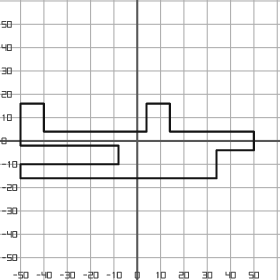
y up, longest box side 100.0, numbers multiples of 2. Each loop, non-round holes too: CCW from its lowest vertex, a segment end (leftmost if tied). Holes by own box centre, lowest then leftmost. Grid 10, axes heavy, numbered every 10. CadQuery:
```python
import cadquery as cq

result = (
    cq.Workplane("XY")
    .moveTo(-50.0, -16.0)
    .lineTo(34.0, -16.0)
    .lineTo(34.0, -4.0)
    .lineTo(50.0, -4.0)
    .lineTo(50.0, 4.0)
    .lineTo(14.0, 4.0)
    .lineTo(14.0, 16.0)
    .lineTo(4.0, 16.0)
    .lineTo(4.0, 4.0)
    .lineTo(-40.0, 4.0)
    .lineTo(-40.0, 16.0)
    .lineTo(-50.0, 16.0)
    .lineTo(-50.0, -2.0)
    .lineTo(-8.0, -2.0)
    .lineTo(-8.0, -10.0)
    .lineTo(-50.0, -10.0)
    .close()
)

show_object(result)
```